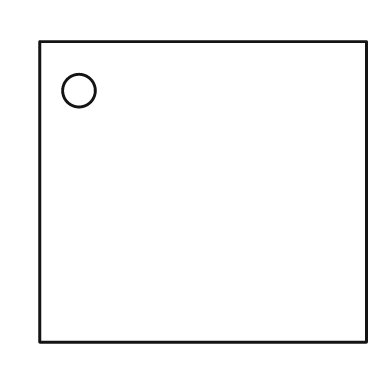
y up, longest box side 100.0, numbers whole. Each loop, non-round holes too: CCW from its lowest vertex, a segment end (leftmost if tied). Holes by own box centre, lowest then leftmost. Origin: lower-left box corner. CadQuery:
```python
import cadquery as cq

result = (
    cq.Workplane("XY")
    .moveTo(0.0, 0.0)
    .lineTo(100.0, 0.0)
    .lineTo(100.0, 92.0)
    .lineTo(0.0, 92.0)
    .close()
    .moveTo(12.0, 77.0)
    .circle(5.0)
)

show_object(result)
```